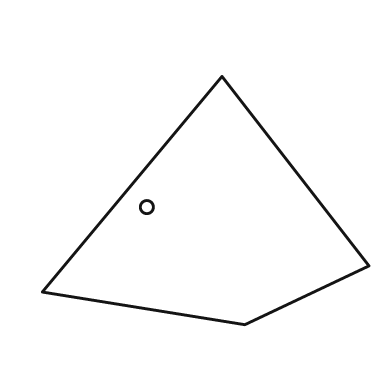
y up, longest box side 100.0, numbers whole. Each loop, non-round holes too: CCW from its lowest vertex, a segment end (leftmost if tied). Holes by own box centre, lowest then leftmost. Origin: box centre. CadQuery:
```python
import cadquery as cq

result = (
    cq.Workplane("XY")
    .moveTo(12.0, -38.0)
    .lineTo(50.0, -20.0)
    .lineTo(5.0, 38.0)
    .lineTo(-50.0, -28.0)
    .close()
    .moveTo(-18.0, -2.0)
    .circle(2.0)
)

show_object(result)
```